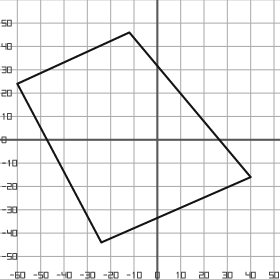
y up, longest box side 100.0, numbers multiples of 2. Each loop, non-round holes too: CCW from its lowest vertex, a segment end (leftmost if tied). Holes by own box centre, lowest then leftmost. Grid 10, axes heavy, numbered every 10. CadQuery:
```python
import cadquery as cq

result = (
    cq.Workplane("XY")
    .moveTo(-24.0, -44.0)
    .lineTo(40.0, -16.0)
    .lineTo(-12.0, 46.0)
    .lineTo(-60.0, 24.0)
    .close()
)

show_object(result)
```